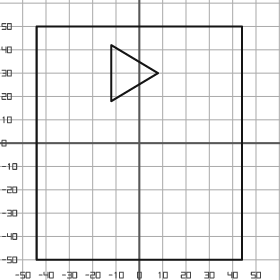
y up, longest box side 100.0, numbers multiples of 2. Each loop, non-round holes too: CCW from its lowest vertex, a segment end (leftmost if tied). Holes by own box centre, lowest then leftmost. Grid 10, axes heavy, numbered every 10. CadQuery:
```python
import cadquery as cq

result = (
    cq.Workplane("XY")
    .moveTo(-44.0, -50.0)
    .lineTo(44.0, -50.0)
    .lineTo(44.0, 50.0)
    .lineTo(-44.0, 50.0)
    .close()
    .moveTo(-12.0, 18.0)
    .lineTo(8.0, 30.0)
    .lineTo(-12.0, 42.0)
    .close()
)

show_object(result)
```